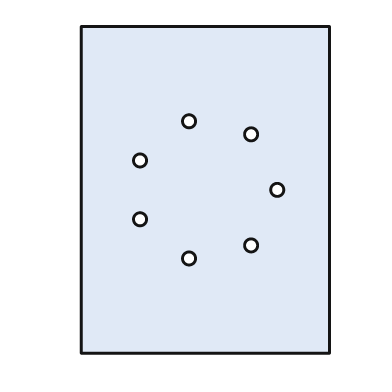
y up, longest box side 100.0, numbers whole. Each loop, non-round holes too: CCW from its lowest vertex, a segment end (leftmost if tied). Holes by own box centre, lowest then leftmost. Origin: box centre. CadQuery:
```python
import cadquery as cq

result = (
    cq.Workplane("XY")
    .moveTo(-38.0, -50.0)
    .lineTo(38.0, -50.0)
    .lineTo(38.0, 50.0)
    .lineTo(-38.0, 50.0)
    .close()
    .moveTo(-5.0, -21.0)
    .circle(2.0)
    .moveTo(14.0, -17.0)
    .circle(2.0)
    .moveTo(-20.0, -9.0)
    .circle(2.0)
    .moveTo(22.0, 0.0)
    .circle(2.0)
    .moveTo(-20.0, 9.0)
    .circle(2.0)
    .moveTo(14.0, 17.0)
    .circle(2.0)
    .moveTo(-5.0, 21.0)
    .circle(2.0)
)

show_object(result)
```